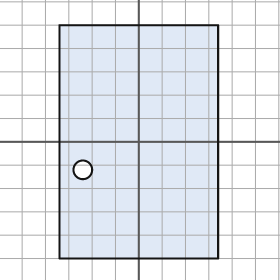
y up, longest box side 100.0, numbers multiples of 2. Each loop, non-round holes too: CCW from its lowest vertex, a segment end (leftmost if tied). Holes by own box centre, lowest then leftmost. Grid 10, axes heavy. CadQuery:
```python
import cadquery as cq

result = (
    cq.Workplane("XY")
    .moveTo(-34.0, -50.0)
    .lineTo(34.0, -50.0)
    .lineTo(34.0, 50.0)
    .lineTo(-34.0, 50.0)
    .close()
    .moveTo(-24.0, -12.0)
    .circle(4.0)
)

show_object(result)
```